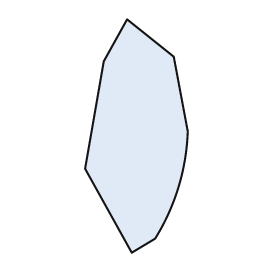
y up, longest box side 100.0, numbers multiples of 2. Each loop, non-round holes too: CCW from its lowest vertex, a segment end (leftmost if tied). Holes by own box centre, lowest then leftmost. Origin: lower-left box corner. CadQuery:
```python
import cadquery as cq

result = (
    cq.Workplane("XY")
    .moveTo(20.0, 0.0)
    .lineTo(30.0, 6.0)
    .threePointArc((40.0, 28.0), (44.0, 52.0))
    .lineTo(38.0, 84.0)
    .lineTo(18.0, 100.0)
    .lineTo(8.0, 82.0)
    .lineTo(0.0, 36.0)
    .close()
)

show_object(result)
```